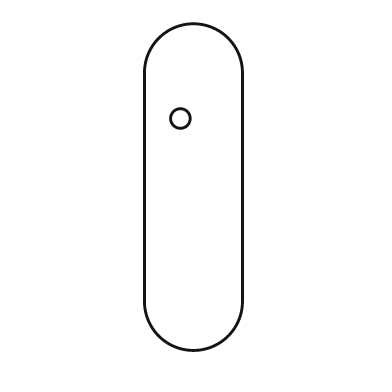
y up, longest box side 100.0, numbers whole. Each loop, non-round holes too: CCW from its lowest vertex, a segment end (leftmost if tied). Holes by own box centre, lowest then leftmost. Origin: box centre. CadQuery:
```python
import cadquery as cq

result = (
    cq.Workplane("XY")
    .moveTo(-15.0, -35.0)
    .threePointArc((0.0, -50.0), (15.0, -35.0))
    .lineTo(15.0, 35.0)
    .threePointArc((0.0, 50.0), (-15.0, 35.0))
    .close()
    .moveTo(-4.0, 21.0)
    .circle(3.0)
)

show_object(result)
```